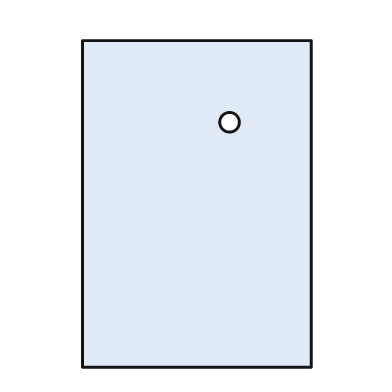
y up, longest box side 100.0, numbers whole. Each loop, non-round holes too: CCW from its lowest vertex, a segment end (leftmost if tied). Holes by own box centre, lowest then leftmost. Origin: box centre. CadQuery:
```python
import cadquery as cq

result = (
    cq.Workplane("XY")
    .moveTo(-35.0, -50.0)
    .lineTo(35.0, -50.0)
    .lineTo(35.0, 50.0)
    .lineTo(-35.0, 50.0)
    .close()
    .moveTo(10.0, 25.0)
    .circle(3.0)
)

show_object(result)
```